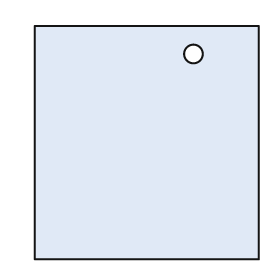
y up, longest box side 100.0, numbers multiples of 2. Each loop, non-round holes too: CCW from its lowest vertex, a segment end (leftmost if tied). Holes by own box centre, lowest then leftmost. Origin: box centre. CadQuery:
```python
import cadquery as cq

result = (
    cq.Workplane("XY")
    .moveTo(-48.0, -50.0)
    .lineTo(48.0, -50.0)
    .lineTo(48.0, 50.0)
    .lineTo(-48.0, 50.0)
    .close()
    .moveTo(20.0, 38.0)
    .circle(4.0)
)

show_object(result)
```